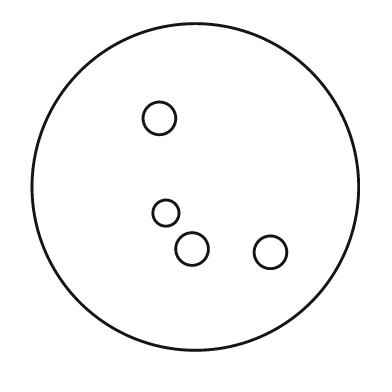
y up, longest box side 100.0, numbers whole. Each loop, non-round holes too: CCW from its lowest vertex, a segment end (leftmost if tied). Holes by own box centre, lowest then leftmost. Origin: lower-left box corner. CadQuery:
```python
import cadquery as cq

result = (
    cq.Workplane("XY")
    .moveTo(50.0, 50.0)
    .circle(50.0)
    .moveTo(73.0, 30.0)
    .circle(5.0)
    .moveTo(49.0, 31.0)
    .circle(5.0)
    .moveTo(41.0, 42.0)
    .circle(4.0)
    .moveTo(39.0, 71.0)
    .circle(5.0)
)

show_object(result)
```